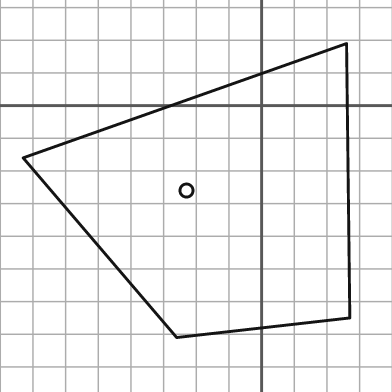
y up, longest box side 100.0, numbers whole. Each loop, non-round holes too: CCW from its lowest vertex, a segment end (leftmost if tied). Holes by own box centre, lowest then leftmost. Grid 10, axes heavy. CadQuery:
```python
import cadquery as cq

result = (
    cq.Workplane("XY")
    .moveTo(-26.0, -71.0)
    .lineTo(27.0, -65.0)
    .lineTo(26.0, 19.0)
    .lineTo(-73.0, -16.0)
    .close()
    .moveTo(-23.0, -26.0)
    .circle(2.0)
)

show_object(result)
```